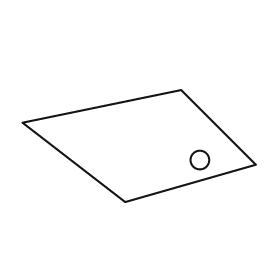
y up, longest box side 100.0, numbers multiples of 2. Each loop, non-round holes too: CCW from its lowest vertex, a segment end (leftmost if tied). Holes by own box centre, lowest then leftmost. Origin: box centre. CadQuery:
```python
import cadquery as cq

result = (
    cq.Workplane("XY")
    .moveTo(-6.0, -24.0)
    .lineTo(50.0, -8.0)
    .lineTo(18.0, 24.0)
    .lineTo(-50.0, 10.0)
    .close()
    .moveTo(26.0, -6.0)
    .circle(4.0)
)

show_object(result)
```